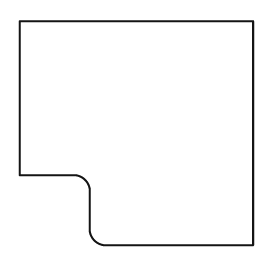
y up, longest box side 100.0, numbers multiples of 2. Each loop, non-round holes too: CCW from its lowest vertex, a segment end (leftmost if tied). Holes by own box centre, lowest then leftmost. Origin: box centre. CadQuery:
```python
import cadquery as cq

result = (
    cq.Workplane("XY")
    .moveTo(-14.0, -48.0)
    .lineTo(50.0, -48.0)
    .lineTo(50.0, 48.0)
    .lineTo(-50.0, 48.0)
    .lineTo(-50.0, -18.0)
    .lineTo(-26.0, -18.0)
    .threePointArc((-22.0, -20.0), (-20.0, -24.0))
    .lineTo(-20.0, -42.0)
    .threePointArc((-18.0, -46.0), (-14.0, -48.0))
    .close()
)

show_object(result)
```